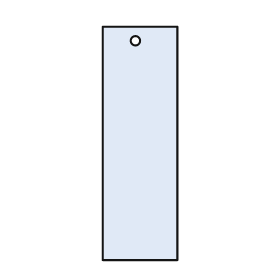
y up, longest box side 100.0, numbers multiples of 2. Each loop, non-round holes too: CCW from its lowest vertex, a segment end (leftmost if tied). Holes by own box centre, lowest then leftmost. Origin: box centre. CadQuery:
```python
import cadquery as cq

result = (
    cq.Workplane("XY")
    .moveTo(-16.0, -50.0)
    .lineTo(16.0, -50.0)
    .lineTo(16.0, 50.0)
    .lineTo(-16.0, 50.0)
    .close()
    .moveTo(-2.0, 44.0)
    .circle(2.0)
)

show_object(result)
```